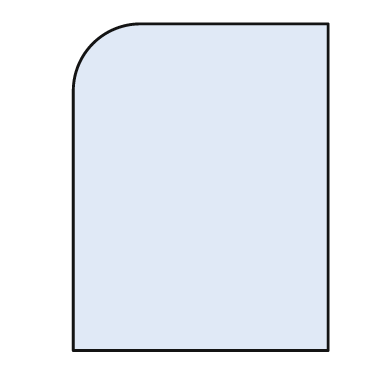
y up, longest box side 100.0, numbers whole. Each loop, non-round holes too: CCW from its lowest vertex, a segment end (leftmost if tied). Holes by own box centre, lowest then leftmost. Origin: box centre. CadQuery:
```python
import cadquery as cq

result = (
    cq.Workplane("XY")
    .moveTo(-39.0, -50.0)
    .lineTo(39.0, -50.0)
    .lineTo(39.0, 50.0)
    .lineTo(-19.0, 50.0)
    .threePointArc((-33.0, 44.0), (-39.0, 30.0))
    .close()
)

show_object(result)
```